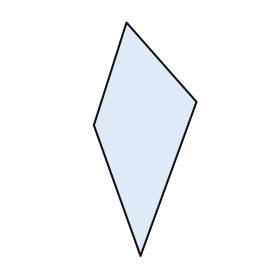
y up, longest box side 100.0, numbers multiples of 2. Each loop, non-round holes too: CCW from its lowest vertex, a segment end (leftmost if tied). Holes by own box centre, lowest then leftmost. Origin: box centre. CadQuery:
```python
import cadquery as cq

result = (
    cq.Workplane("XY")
    .moveTo(-2.0, -50.0)
    .lineTo(22.0, 16.0)
    .lineTo(-8.0, 50.0)
    .lineTo(-22.0, 6.0)
    .close()
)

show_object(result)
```